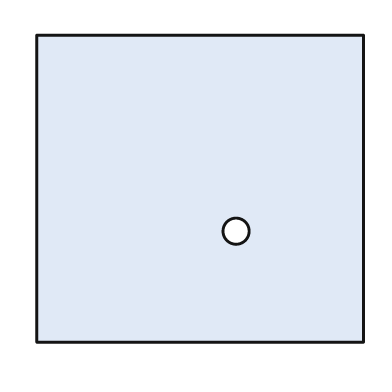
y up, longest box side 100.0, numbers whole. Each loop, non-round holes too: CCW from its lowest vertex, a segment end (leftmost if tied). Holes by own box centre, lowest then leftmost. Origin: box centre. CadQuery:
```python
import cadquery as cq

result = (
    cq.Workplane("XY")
    .moveTo(-50.0, -47.0)
    .lineTo(50.0, -47.0)
    .lineTo(50.0, 47.0)
    .lineTo(-50.0, 47.0)
    .close()
    .moveTo(11.0, -13.0)
    .circle(4.0)
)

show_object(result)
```